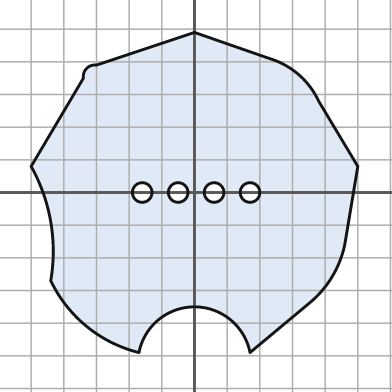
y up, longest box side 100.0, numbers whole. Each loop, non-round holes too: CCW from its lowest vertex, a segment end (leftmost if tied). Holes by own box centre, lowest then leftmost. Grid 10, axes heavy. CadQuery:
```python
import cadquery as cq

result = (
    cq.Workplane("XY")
    .moveTo(-17.0, -49.0)
    .threePointArc((0.0, -35.0), (17.0, -49.0))
    .lineTo(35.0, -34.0)
    .threePointArc((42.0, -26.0), (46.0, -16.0))
    .lineTo(50.0, 8.0)
    .lineTo(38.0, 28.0)
    .threePointArc((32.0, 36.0), (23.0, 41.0))
    .lineTo(0.0, 49.0)
    .lineTo(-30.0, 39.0)
    .threePointArc((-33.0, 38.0), (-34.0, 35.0))
    .lineTo(-50.0, 8.0)
    .threePointArc((-44.0, -9.0), (-44.0, -27.0))
    .threePointArc((-33.0, -41.0), (-17.0, -49.0))
    .close()
    .moveTo(-16.0, 0.0)
    .circle(3.0)
    .moveTo(-5.0, 0.0)
    .circle(3.0)
    .moveTo(6.0, 0.0)
    .circle(3.0)
    .moveTo(17.0, 0.0)
    .circle(3.0)
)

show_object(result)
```